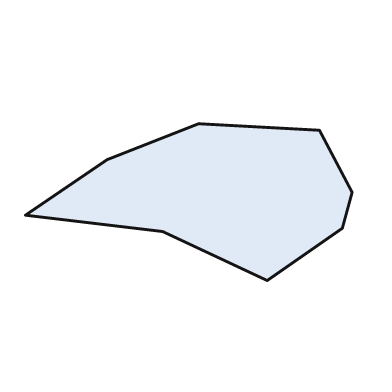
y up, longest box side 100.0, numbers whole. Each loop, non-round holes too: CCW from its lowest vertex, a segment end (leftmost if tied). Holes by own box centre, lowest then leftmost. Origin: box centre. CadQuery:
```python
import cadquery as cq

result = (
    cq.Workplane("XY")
    .moveTo(24.0, -24.0)
    .lineTo(47.0, -8.0)
    .lineTo(50.0, 3.0)
    .lineTo(40.0, 22.0)
    .lineTo(3.0, 24.0)
    .lineTo(-25.0, 13.0)
    .lineTo(-50.0, -4.0)
    .lineTo(-8.0, -9.0)
    .close()
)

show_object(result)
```